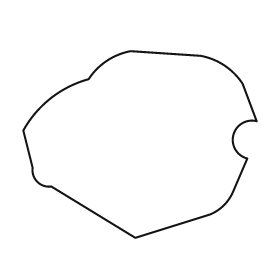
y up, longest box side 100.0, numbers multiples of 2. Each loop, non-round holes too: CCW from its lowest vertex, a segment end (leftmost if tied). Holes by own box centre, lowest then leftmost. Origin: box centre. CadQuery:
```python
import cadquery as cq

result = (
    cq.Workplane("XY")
    .moveTo(-2.0, -40.0)
    .lineTo(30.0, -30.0)
    .threePointArc((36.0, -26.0), (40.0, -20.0))
    .lineTo(46.0, -6.0)
    .threePointArc((40.0, 4.0), (50.0, 10.0))
    .lineTo(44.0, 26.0)
    .threePointArc((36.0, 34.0), (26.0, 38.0))
    .lineTo(-4.0, 40.0)
    .threePointArc((-14.0, 36.0), (-22.0, 28.0))
    .threePointArc((-38.0, 20.0), (-50.0, 6.0))
    .lineTo(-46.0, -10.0)
    .threePointArc((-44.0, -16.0), (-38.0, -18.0))
    .close()
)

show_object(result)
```